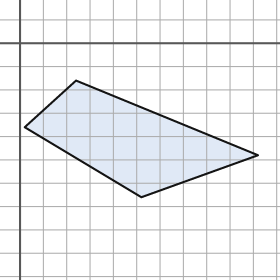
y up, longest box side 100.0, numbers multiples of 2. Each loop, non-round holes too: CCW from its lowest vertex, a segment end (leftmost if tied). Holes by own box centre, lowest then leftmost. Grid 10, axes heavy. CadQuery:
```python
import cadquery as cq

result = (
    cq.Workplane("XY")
    .moveTo(52.0, -66.0)
    .lineTo(102.0, -48.0)
    .lineTo(24.0, -16.0)
    .lineTo(2.0, -36.0)
    .close()
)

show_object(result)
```